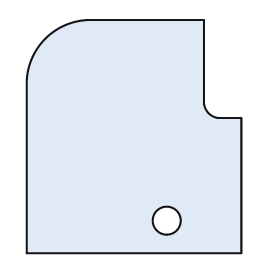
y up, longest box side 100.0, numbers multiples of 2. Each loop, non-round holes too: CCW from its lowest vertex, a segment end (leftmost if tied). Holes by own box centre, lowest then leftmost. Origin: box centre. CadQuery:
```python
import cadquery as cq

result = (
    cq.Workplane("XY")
    .moveTo(-46.0, -50.0)
    .lineTo(46.0, -50.0)
    .lineTo(46.0, 8.0)
    .lineTo(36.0, 8.0)
    .threePointArc((32.0, 10.0), (30.0, 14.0))
    .lineTo(30.0, 50.0)
    .lineTo(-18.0, 50.0)
    .threePointArc((-38.0, 42.0), (-46.0, 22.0))
    .close()
    .moveTo(14.0, -36.0)
    .circle(6.0)
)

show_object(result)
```